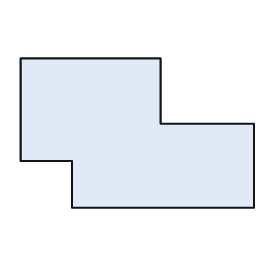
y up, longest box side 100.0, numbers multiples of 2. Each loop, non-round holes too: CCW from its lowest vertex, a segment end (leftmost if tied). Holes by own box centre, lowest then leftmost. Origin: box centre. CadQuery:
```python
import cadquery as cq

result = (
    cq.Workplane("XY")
    .moveTo(-28.0, -32.0)
    .lineTo(50.0, -32.0)
    .lineTo(50.0, 4.0)
    .lineTo(10.0, 4.0)
    .lineTo(10.0, 32.0)
    .lineTo(-50.0, 32.0)
    .lineTo(-50.0, -12.0)
    .lineTo(-28.0, -12.0)
    .close()
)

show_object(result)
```